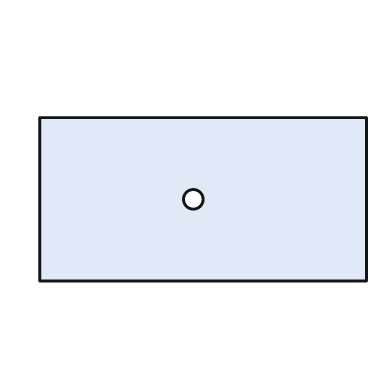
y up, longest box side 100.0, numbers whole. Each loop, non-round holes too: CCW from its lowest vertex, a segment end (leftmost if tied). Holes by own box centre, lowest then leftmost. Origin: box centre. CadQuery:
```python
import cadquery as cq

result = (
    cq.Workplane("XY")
    .moveTo(-50.0, -25.0)
    .lineTo(50.0, -25.0)
    .lineTo(50.0, 25.0)
    .lineTo(-50.0, 25.0)
    .close()
    .moveTo(-3.0, 0.0)
    .circle(3.0)
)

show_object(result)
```